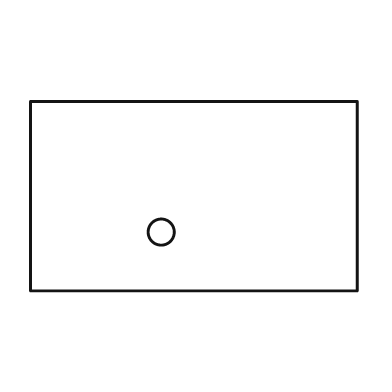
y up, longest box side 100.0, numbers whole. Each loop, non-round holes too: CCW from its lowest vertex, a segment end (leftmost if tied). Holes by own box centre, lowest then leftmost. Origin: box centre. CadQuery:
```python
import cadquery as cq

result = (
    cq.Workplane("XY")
    .moveTo(-50.0, -29.0)
    .lineTo(50.0, -29.0)
    .lineTo(50.0, 29.0)
    .lineTo(-50.0, 29.0)
    .close()
    .moveTo(-10.0, -11.0)
    .circle(4.0)
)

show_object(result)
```